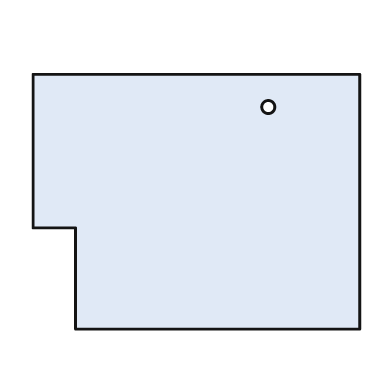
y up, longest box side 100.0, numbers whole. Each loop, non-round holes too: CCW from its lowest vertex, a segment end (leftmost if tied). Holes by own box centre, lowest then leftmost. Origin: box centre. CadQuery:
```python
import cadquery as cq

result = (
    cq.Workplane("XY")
    .moveTo(-37.0, -39.0)
    .lineTo(50.0, -39.0)
    .lineTo(50.0, 39.0)
    .lineTo(-50.0, 39.0)
    .lineTo(-50.0, -8.0)
    .lineTo(-37.0, -8.0)
    .close()
    .moveTo(22.0, 29.0)
    .circle(2.0)
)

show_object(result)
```